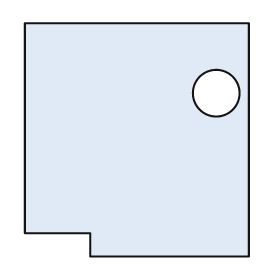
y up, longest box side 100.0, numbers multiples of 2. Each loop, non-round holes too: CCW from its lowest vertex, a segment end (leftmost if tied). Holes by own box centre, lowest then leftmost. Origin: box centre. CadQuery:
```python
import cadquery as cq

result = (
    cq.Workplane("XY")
    .moveTo(-20.0, -50.0)
    .lineTo(48.0, -50.0)
    .lineTo(48.0, 50.0)
    .lineTo(-48.0, 50.0)
    .lineTo(-48.0, -40.0)
    .lineTo(-20.0, -40.0)
    .close()
    .moveTo(34.0, 20.0)
    .circle(10.0)
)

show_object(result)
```